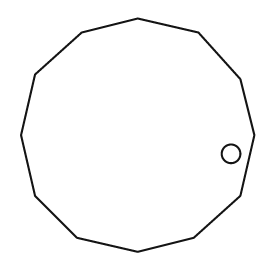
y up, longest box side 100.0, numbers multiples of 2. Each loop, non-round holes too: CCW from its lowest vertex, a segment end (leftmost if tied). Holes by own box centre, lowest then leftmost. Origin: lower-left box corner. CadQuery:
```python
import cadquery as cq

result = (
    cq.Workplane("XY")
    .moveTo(50.0, 0.0)
    .lineTo(74.0, 6.0)
    .lineTo(94.0, 24.0)
    .lineTo(100.0, 50.0)
    .lineTo(94.0, 74.0)
    .lineTo(76.0, 94.0)
    .lineTo(50.0, 100.0)
    .lineTo(26.0, 94.0)
    .lineTo(6.0, 76.0)
    .lineTo(0.0, 50.0)
    .lineTo(6.0, 24.0)
    .lineTo(24.0, 6.0)
    .close()
    .moveTo(90.0, 42.0)
    .circle(4.0)
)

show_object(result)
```